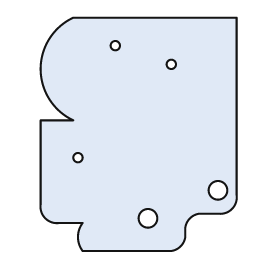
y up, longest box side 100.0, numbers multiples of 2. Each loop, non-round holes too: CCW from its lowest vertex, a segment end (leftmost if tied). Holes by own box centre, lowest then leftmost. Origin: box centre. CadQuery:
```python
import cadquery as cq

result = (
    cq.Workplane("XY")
    .moveTo(-24.0, -50.0)
    .lineTo(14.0, -50.0)
    .threePointArc((18.0, -48.0), (20.0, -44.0))
    .lineTo(20.0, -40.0)
    .threePointArc((22.0, -36.0), (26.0, -34.0))
    .lineTo(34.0, -34.0)
    .threePointArc((40.0, -32.0), (42.0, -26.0))
    .lineTo(42.0, 50.0)
    .lineTo(-28.0, 50.0)
    .threePointArc((-42.0, 28.0), (-28.0, 6.0))
    .lineTo(-42.0, 6.0)
    .lineTo(-42.0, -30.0)
    .threePointArc((-40.0, -36.0), (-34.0, -38.0))
    .lineTo(-24.0, -38.0)
    .threePointArc((-26.0, -44.0), (-24.0, -50.0))
    .close()
    .moveTo(4.0, -36.0)
    .circle(4.0)
    .moveTo(34.0, -24.0)
    .circle(4.0)
    .moveTo(-26.0, -10.0)
    .circle(2.0)
    .moveTo(14.0, 30.0)
    .circle(2.0)
    .moveTo(-10.0, 38.0)
    .circle(2.0)
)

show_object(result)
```